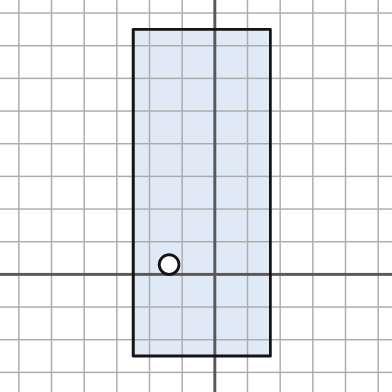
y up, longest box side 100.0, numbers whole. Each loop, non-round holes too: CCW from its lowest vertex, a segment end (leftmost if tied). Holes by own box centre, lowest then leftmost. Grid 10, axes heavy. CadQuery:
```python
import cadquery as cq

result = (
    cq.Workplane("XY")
    .moveTo(-25.0, -25.0)
    .lineTo(17.0, -25.0)
    .lineTo(17.0, 75.0)
    .lineTo(-25.0, 75.0)
    .close()
    .moveTo(-14.0, 3.0)
    .circle(3.0)
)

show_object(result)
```